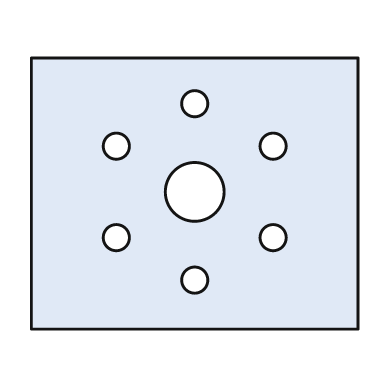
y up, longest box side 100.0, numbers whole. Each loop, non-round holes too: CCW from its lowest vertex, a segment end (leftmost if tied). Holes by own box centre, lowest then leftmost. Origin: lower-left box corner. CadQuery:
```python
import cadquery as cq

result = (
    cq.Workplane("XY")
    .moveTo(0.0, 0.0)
    .lineTo(100.0, 0.0)
    .lineTo(100.0, 83.0)
    .lineTo(0.0, 83.0)
    .close()
    .moveTo(50.0, 15.0)
    .circle(4.0)
    .moveTo(26.0, 28.0)
    .circle(4.0)
    .moveTo(74.0, 28.0)
    .circle(4.0)
    .moveTo(50.0, 42.0)
    .circle(9.0)
    .moveTo(26.0, 56.0)
    .circle(4.0)
    .moveTo(74.0, 56.0)
    .circle(4.0)
    .moveTo(50.0, 69.0)
    .circle(4.0)
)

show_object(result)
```